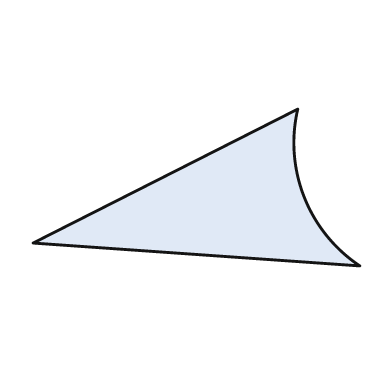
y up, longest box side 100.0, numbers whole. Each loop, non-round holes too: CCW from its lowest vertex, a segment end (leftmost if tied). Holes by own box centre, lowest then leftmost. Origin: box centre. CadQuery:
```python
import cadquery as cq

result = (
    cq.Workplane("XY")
    .moveTo(50.0, -24.0)
    .threePointArc((33.0, -3.0), (31.0, 24.0))
    .lineTo(-50.0, -17.0)
    .close()
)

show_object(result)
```